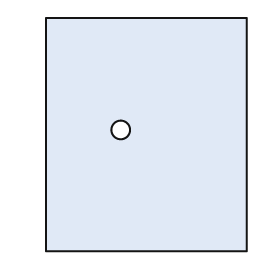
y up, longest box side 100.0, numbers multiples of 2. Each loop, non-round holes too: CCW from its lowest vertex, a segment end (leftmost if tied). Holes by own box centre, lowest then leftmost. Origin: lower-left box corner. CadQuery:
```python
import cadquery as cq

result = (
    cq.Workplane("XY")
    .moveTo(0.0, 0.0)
    .lineTo(86.0, 0.0)
    .lineTo(86.0, 100.0)
    .lineTo(0.0, 100.0)
    .close()
    .moveTo(32.0, 52.0)
    .circle(4.0)
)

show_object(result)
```